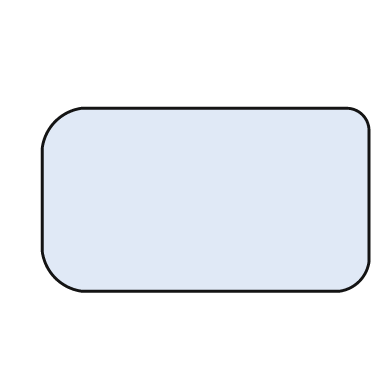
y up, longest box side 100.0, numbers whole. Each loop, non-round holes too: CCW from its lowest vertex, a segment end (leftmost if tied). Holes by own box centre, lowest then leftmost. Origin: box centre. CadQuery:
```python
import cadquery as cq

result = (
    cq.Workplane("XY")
    .moveTo(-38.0, -28.0)
    .lineTo(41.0, -28.0)
    .threePointArc((47.0, -25.0), (50.0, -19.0))
    .lineTo(50.0, 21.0)
    .threePointArc((48.0, 26.0), (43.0, 28.0))
    .lineTo(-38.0, 28.0)
    .threePointArc((-46.0, 24.0), (-50.0, 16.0))
    .lineTo(-50.0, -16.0)
    .threePointArc((-46.0, -24.0), (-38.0, -28.0))
    .close()
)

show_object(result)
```